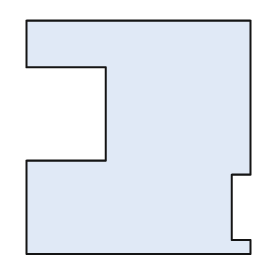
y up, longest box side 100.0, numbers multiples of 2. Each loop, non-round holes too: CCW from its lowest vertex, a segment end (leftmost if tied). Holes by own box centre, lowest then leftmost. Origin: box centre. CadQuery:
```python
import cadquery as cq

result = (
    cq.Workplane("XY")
    .moveTo(-48.0, -50.0)
    .lineTo(48.0, -50.0)
    .lineTo(48.0, -44.0)
    .lineTo(40.0, -44.0)
    .lineTo(40.0, -16.0)
    .lineTo(48.0, -16.0)
    .lineTo(48.0, 50.0)
    .lineTo(-48.0, 50.0)
    .lineTo(-48.0, 30.0)
    .lineTo(-14.0, 30.0)
    .lineTo(-14.0, -10.0)
    .lineTo(-48.0, -10.0)
    .close()
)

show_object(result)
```